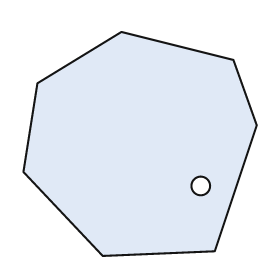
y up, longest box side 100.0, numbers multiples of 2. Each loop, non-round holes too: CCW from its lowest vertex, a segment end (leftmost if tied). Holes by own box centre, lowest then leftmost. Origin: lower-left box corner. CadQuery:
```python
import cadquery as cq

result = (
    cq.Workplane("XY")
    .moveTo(34.0, 0.0)
    .lineTo(82.0, 2.0)
    .lineTo(100.0, 56.0)
    .lineTo(90.0, 84.0)
    .lineTo(42.0, 96.0)
    .lineTo(6.0, 74.0)
    .lineTo(0.0, 36.0)
    .close()
    .moveTo(76.0, 30.0)
    .circle(4.0)
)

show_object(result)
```